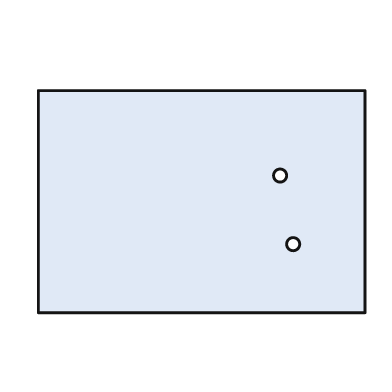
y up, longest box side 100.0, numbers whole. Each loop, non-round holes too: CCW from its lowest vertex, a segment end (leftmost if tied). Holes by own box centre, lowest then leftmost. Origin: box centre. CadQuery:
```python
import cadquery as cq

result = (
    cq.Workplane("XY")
    .moveTo(-50.0, -34.0)
    .lineTo(50.0, -34.0)
    .lineTo(50.0, 34.0)
    .lineTo(-50.0, 34.0)
    .close()
    .moveTo(28.0, -13.0)
    .circle(2.0)
    .moveTo(24.0, 8.0)
    .circle(2.0)
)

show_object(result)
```